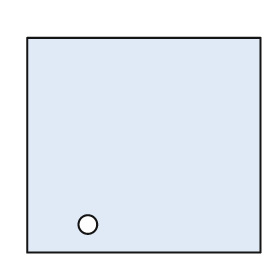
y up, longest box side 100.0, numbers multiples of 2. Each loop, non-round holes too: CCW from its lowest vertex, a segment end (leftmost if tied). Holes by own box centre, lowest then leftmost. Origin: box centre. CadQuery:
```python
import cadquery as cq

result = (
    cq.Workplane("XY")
    .moveTo(-50.0, -46.0)
    .lineTo(50.0, -46.0)
    .lineTo(50.0, 46.0)
    .lineTo(-50.0, 46.0)
    .close()
    .moveTo(-24.0, -34.0)
    .circle(4.0)
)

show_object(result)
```